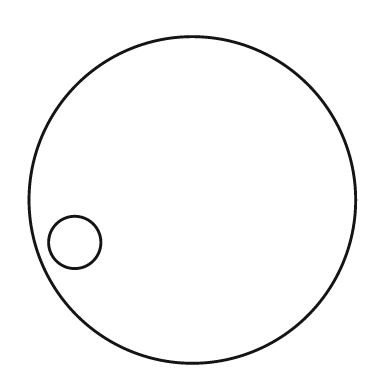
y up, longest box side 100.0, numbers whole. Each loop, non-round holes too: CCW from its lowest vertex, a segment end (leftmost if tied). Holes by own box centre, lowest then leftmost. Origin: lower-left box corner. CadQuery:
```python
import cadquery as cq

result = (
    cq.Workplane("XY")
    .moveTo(50.0, 50.0)
    .circle(50.0)
    .moveTo(14.0, 37.0)
    .circle(8.0)
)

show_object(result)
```